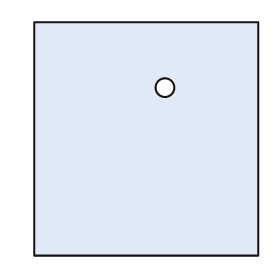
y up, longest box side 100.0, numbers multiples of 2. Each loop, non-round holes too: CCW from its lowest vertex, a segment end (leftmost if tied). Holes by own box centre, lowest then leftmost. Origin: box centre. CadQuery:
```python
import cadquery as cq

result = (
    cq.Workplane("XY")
    .moveTo(-48.0, -50.0)
    .lineTo(48.0, -50.0)
    .lineTo(48.0, 50.0)
    .lineTo(-48.0, 50.0)
    .close()
    .moveTo(8.0, 22.0)
    .circle(4.0)
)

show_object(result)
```